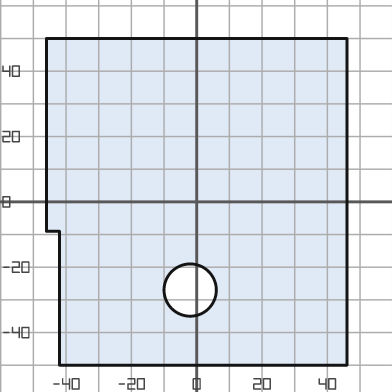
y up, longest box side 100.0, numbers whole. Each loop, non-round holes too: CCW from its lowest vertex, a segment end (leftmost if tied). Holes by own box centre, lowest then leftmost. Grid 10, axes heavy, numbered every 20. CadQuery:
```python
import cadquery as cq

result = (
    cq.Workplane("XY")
    .moveTo(-42.0, -50.0)
    .lineTo(46.0, -50.0)
    .lineTo(46.0, 50.0)
    .lineTo(-46.0, 50.0)
    .lineTo(-46.0, -9.0)
    .lineTo(-42.0, -9.0)
    .close()
    .moveTo(-2.0, -27.0)
    .circle(8.0)
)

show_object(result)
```